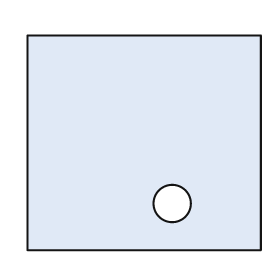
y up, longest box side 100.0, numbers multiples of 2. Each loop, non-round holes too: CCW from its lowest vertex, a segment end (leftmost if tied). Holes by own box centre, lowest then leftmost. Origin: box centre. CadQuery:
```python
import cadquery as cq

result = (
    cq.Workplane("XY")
    .moveTo(-50.0, -46.0)
    .lineTo(50.0, -46.0)
    .lineTo(50.0, 46.0)
    .lineTo(-50.0, 46.0)
    .close()
    .moveTo(12.0, -26.0)
    .circle(8.0)
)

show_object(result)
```